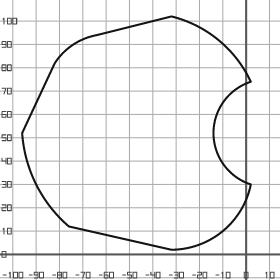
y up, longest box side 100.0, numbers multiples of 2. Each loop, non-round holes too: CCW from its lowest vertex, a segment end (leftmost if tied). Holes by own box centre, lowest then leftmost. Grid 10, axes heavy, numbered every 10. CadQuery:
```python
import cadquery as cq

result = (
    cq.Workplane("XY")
    .moveTo(-32.0, 2.0)
    .threePointArc((-10.0, 10.0), (2.0, 30.0))
    .threePointArc((-14.0, 52.0), (2.0, 74.0))
    .threePointArc((-12.0, 92.0), (-32.0, 102.0))
    .lineTo(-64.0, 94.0)
    .threePointArc((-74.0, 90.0), (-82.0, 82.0))
    .lineTo(-96.0, 52.0)
    .threePointArc((-90.0, 30.0), (-76.0, 12.0))
    .close()
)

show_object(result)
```